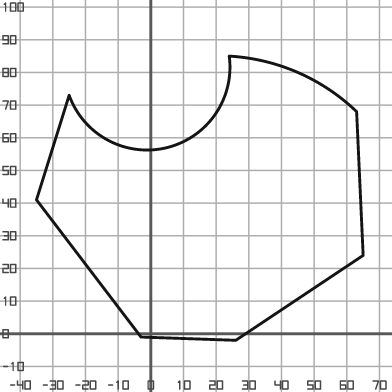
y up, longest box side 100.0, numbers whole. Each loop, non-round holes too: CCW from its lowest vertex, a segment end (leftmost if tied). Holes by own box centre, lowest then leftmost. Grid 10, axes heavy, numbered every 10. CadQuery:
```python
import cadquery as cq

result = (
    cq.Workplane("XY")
    .moveTo(26.0, -2.0)
    .lineTo(65.0, 24.0)
    .lineTo(63.0, 68.0)
    .threePointArc((45.0, 80.0), (24.0, 85.0))
    .threePointArc((5.0, 57.0), (-25.0, 73.0))
    .lineTo(-35.0, 41.0)
    .lineTo(-3.0, -1.0)
    .close()
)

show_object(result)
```